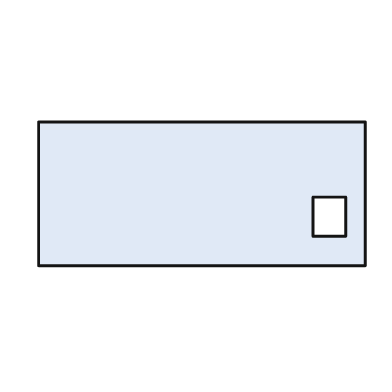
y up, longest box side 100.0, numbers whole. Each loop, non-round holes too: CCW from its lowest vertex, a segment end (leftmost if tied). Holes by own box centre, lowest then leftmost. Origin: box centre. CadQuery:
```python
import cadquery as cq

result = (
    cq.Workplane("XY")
    .moveTo(-50.0, -22.0)
    .lineTo(50.0, -22.0)
    .lineTo(50.0, 22.0)
    .lineTo(-50.0, 22.0)
    .close()
    .moveTo(34.0, -13.0)
    .lineTo(44.0, -13.0)
    .lineTo(44.0, -1.0)
    .lineTo(34.0, -1.0)
    .close()
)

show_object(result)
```